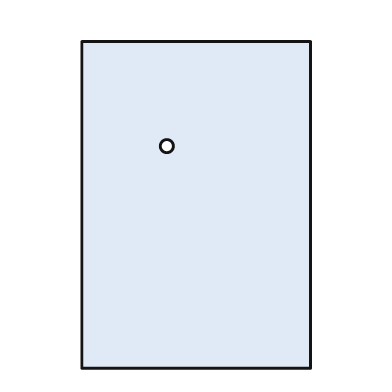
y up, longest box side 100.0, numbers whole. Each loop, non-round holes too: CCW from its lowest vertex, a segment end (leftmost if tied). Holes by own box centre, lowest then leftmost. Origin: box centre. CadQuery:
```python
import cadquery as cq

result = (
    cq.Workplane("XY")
    .moveTo(-35.0, -50.0)
    .lineTo(35.0, -50.0)
    .lineTo(35.0, 50.0)
    .lineTo(-35.0, 50.0)
    .close()
    .moveTo(-9.0, 18.0)
    .circle(2.0)
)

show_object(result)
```